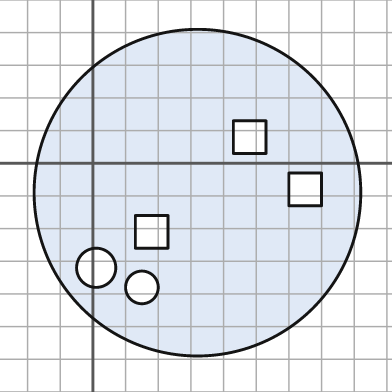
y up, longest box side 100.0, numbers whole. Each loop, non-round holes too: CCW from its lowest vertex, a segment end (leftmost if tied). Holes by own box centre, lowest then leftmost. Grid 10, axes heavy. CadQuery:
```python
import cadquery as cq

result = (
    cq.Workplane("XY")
    .moveTo(32.0, -9.0)
    .circle(50.0)
    .moveTo(15.0, -38.0)
    .circle(5.0)
    .moveTo(1.0, -32.0)
    .circle(6.0)
    .moveTo(13.0, -26.0)
    .lineTo(23.0, -26.0)
    .lineTo(23.0, -16.0)
    .lineTo(13.0, -16.0)
    .close()
    .moveTo(60.0, -13.0)
    .lineTo(70.0, -13.0)
    .lineTo(70.0, -3.0)
    .lineTo(60.0, -3.0)
    .close()
    .moveTo(43.0, 3.0)
    .lineTo(53.0, 3.0)
    .lineTo(53.0, 13.0)
    .lineTo(43.0, 13.0)
    .close()
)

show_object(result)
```